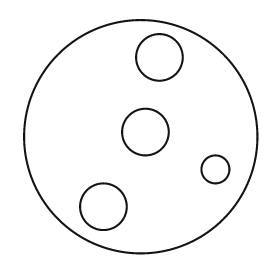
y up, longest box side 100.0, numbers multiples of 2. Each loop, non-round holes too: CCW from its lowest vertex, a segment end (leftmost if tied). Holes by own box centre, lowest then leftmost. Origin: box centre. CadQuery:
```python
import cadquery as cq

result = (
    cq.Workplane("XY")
    .moveTo(0.0, 0.0)
    .circle(50.0)
    .moveTo(-16.0, -30.0)
    .circle(10.0)
    .moveTo(32.0, -14.0)
    .circle(6.0)
    .moveTo(2.0, 2.0)
    .circle(10.0)
    .moveTo(8.0, 34.0)
    .circle(10.0)
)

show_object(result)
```